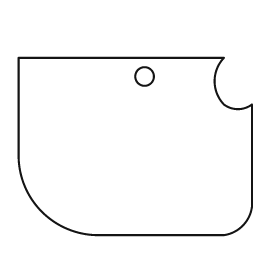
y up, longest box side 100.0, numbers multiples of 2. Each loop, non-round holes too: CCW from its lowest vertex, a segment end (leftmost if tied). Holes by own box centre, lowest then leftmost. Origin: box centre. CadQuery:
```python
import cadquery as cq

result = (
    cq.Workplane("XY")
    .moveTo(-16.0, -38.0)
    .lineTo(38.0, -38.0)
    .threePointArc((46.0, -34.0), (50.0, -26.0))
    .lineTo(50.0, 18.0)
    .threePointArc((44.0, 16.0), (38.0, 18.0))
    .threePointArc((34.0, 28.0), (38.0, 38.0))
    .lineTo(-50.0, 38.0)
    .lineTo(-50.0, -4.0)
    .threePointArc((-40.0, -28.0), (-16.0, -38.0))
    .close()
    .moveTo(4.0, 30.0)
    .circle(4.0)
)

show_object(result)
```